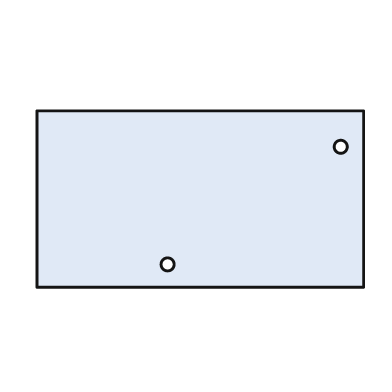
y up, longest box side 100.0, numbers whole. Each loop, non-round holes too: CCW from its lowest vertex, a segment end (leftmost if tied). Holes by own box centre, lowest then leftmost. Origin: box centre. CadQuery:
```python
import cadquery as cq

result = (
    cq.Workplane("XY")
    .moveTo(-50.0, -27.0)
    .lineTo(50.0, -27.0)
    .lineTo(50.0, 27.0)
    .lineTo(-50.0, 27.0)
    .close()
    .moveTo(-10.0, -20.0)
    .circle(2.0)
    .moveTo(43.0, 16.0)
    .circle(2.0)
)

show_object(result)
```